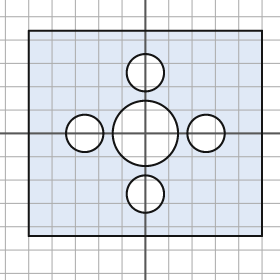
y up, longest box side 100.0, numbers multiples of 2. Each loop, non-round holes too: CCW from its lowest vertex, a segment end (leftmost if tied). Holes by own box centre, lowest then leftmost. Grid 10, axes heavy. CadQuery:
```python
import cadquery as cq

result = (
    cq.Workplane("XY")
    .moveTo(-50.0, -44.0)
    .lineTo(50.0, -44.0)
    .lineTo(50.0, 44.0)
    .lineTo(-50.0, 44.0)
    .close()
    .moveTo(0.0, -26.0)
    .circle(8.0)
    .moveTo(-26.0, 0.0)
    .circle(8.0)
    .moveTo(0.0, 0.0)
    .circle(14.0)
    .moveTo(26.0, 0.0)
    .circle(8.0)
    .moveTo(0.0, 26.0)
    .circle(8.0)
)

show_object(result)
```